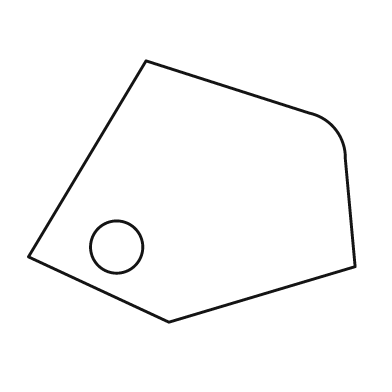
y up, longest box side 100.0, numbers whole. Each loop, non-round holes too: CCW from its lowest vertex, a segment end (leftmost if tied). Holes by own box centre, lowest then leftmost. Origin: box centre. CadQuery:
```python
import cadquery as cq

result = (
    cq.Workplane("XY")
    .moveTo(-7.0, -40.0)
    .lineTo(50.0, -23.0)
    .lineTo(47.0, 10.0)
    .threePointArc((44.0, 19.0), (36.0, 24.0))
    .lineTo(-14.0, 40.0)
    .lineTo(-50.0, -20.0)
    .close()
    .moveTo(-23.0, -17.0)
    .circle(8.0)
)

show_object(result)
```